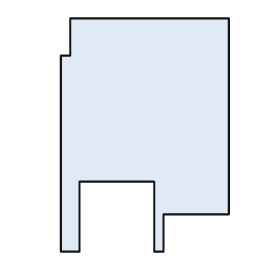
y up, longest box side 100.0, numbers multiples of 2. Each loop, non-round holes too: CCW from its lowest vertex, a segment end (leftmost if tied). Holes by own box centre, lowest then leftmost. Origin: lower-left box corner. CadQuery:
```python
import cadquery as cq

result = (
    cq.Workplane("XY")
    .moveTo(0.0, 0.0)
    .lineTo(8.0, 0.0)
    .lineTo(8.0, 30.0)
    .lineTo(40.0, 30.0)
    .lineTo(40.0, 0.0)
    .lineTo(44.0, 0.0)
    .lineTo(44.0, 16.0)
    .lineTo(72.0, 16.0)
    .lineTo(72.0, 100.0)
    .lineTo(4.0, 100.0)
    .lineTo(4.0, 84.0)
    .lineTo(0.0, 84.0)
    .close()
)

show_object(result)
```